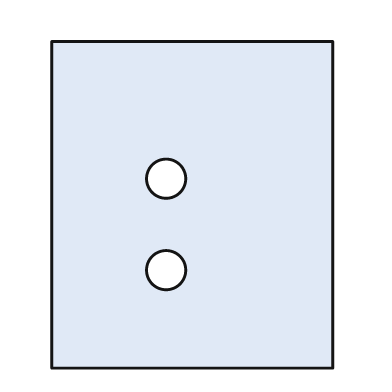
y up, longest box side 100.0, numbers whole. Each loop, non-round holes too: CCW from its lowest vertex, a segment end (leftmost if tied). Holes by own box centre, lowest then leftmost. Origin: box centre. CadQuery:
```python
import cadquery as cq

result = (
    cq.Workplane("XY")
    .moveTo(-43.0, -50.0)
    .lineTo(43.0, -50.0)
    .lineTo(43.0, 50.0)
    .lineTo(-43.0, 50.0)
    .close()
    .moveTo(-8.0, -20.0)
    .circle(6.0)
    .moveTo(-8.0, 8.0)
    .circle(6.0)
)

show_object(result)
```